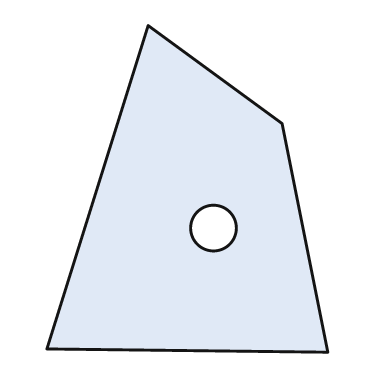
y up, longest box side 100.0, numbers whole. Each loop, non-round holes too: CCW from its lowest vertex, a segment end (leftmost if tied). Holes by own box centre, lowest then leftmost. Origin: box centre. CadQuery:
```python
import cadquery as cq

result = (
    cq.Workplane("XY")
    .moveTo(43.0, -50.0)
    .lineTo(29.0, 20.0)
    .lineTo(-12.0, 50.0)
    .lineTo(-43.0, -49.0)
    .close()
    .moveTo(8.0, -12.0)
    .circle(7.0)
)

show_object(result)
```